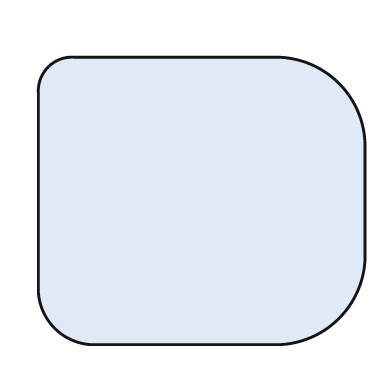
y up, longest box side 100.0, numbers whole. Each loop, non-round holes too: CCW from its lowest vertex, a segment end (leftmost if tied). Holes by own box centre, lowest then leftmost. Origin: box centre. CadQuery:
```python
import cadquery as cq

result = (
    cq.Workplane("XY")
    .moveTo(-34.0, -44.0)
    .lineTo(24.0, -44.0)
    .threePointArc((42.0, -36.0), (50.0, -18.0))
    .lineTo(50.0, 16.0)
    .threePointArc((42.0, 36.0), (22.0, 44.0))
    .lineTo(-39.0, 44.0)
    .threePointArc((-47.0, 41.0), (-50.0, 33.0))
    .lineTo(-50.0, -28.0)
    .threePointArc((-45.0, -39.0), (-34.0, -44.0))
    .close()
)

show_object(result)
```